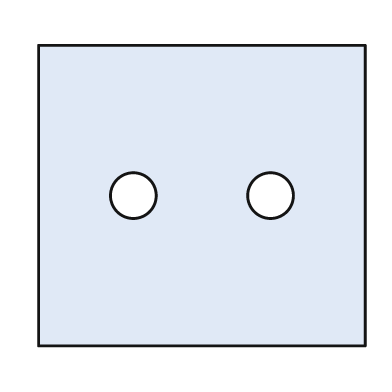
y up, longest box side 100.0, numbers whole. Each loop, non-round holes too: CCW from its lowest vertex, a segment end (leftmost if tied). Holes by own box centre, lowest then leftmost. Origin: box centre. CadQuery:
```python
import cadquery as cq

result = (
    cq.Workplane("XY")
    .moveTo(-50.0, -46.0)
    .lineTo(50.0, -46.0)
    .lineTo(50.0, 46.0)
    .lineTo(-50.0, 46.0)
    .close()
    .moveTo(-21.0, 0.0)
    .circle(7.0)
    .moveTo(21.0, 0.0)
    .circle(7.0)
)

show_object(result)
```